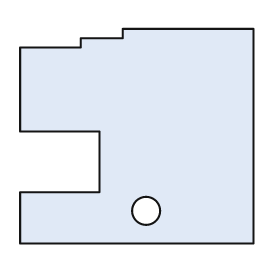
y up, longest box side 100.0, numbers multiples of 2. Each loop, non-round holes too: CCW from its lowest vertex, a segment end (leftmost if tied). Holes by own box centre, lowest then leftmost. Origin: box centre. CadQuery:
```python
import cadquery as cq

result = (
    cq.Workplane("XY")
    .moveTo(-50.0, -46.0)
    .lineTo(50.0, -46.0)
    .lineTo(50.0, 46.0)
    .lineTo(-6.0, 46.0)
    .lineTo(-6.0, 42.0)
    .lineTo(-24.0, 42.0)
    .lineTo(-24.0, 38.0)
    .lineTo(-50.0, 38.0)
    .lineTo(-50.0, 2.0)
    .lineTo(-16.0, 2.0)
    .lineTo(-16.0, -24.0)
    .lineTo(-50.0, -24.0)
    .close()
    .moveTo(4.0, -32.0)
    .circle(6.0)
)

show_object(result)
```